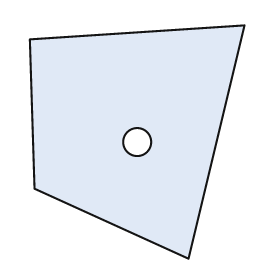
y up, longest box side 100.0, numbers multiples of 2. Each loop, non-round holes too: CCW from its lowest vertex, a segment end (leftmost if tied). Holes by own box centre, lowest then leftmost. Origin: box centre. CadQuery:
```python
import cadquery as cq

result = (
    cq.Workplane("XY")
    .moveTo(22.0, -50.0)
    .lineTo(46.0, 50.0)
    .lineTo(-46.0, 44.0)
    .lineTo(-44.0, -20.0)
    .close()
    .moveTo(0.0, 0.0)
    .circle(6.0)
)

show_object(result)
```